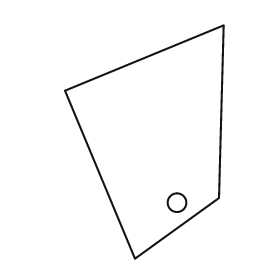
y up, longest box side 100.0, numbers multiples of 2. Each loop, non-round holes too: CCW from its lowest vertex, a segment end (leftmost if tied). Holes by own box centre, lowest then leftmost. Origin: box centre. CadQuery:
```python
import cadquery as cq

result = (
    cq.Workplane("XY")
    .moveTo(-4.0, -50.0)
    .lineTo(32.0, -24.0)
    .lineTo(34.0, 50.0)
    .lineTo(-34.0, 22.0)
    .close()
    .moveTo(14.0, -26.0)
    .circle(4.0)
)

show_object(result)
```